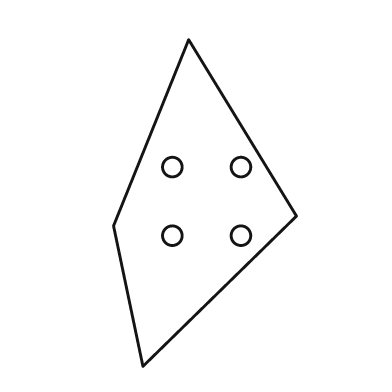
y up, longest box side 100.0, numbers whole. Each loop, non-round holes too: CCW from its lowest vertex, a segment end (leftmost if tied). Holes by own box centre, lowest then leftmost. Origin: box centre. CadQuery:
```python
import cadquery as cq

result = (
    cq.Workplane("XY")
    .moveTo(-19.0, -50.0)
    .lineTo(28.0, -4.0)
    .lineTo(-5.0, 50.0)
    .lineTo(-28.0, -7.0)
    .close()
    .moveTo(-10.0, -10.0)
    .circle(3.0)
    .moveTo(11.0, -10.0)
    .circle(3.0)
    .moveTo(-10.0, 11.0)
    .circle(3.0)
    .moveTo(11.0, 11.0)
    .circle(3.0)
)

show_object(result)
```